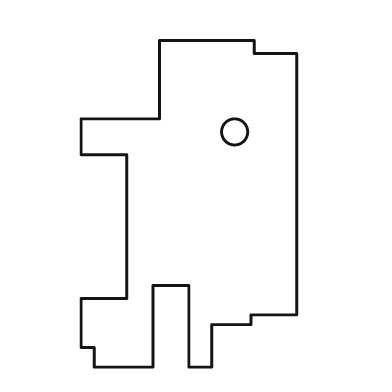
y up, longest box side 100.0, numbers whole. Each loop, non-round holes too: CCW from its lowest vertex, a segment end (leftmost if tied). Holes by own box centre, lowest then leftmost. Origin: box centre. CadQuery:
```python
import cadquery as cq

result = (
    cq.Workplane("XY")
    .moveTo(-29.0, -50.0)
    .lineTo(-11.0, -50.0)
    .lineTo(-11.0, -25.0)
    .lineTo(0.0, -25.0)
    .lineTo(0.0, -50.0)
    .lineTo(7.0, -50.0)
    .lineTo(7.0, -37.0)
    .lineTo(19.0, -37.0)
    .lineTo(19.0, -34.0)
    .lineTo(33.0, -34.0)
    .lineTo(33.0, 46.0)
    .lineTo(20.0, 46.0)
    .lineTo(20.0, 50.0)
    .lineTo(-9.0, 50.0)
    .lineTo(-9.0, 26.0)
    .lineTo(-33.0, 26.0)
    .lineTo(-33.0, 15.0)
    .lineTo(-19.0, 15.0)
    .lineTo(-19.0, -29.0)
    .lineTo(-33.0, -29.0)
    .lineTo(-33.0, -44.0)
    .lineTo(-29.0, -44.0)
    .close()
    .moveTo(14.0, 22.0)
    .circle(4.0)
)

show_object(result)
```